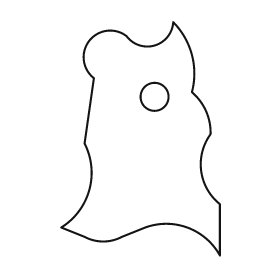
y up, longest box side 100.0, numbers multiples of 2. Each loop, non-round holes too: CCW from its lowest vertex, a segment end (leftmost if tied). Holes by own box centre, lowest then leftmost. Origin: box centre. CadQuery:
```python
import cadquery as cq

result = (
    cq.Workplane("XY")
    .moveTo(34.0, -50.0)
    .lineTo(34.0, -28.0)
    .threePointArc((26.0, -14.0), (30.0, 2.0))
    .threePointArc((28.0, 12.0), (22.0, 20.0))
    .threePointArc((22.0, 36.0), (14.0, 50.0))
    .threePointArc((6.0, 40.0), (-6.0, 44.0))
    .threePointArc((-22.0, 42.0), (-20.0, 26.0))
    .lineTo(-24.0, -2.0)
    .threePointArc((-22.0, -22.0), (-34.0, -38.0))
    .lineTo(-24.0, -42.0)
    .threePointArc((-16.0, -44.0), (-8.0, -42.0))
    .lineTo(2.0, -38.0)
    .threePointArc((20.0, -38.0), (34.0, -50.0))
    .close()
    .moveTo(6.0, 18.0)
    .circle(6.0)
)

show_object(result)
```